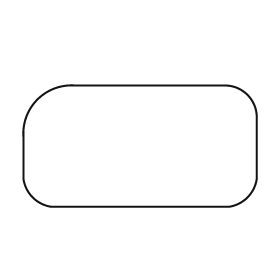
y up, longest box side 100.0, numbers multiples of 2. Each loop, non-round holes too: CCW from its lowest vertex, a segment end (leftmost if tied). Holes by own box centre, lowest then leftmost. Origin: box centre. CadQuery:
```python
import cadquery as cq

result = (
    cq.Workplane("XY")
    .moveTo(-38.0, -26.0)
    .lineTo(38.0, -26.0)
    .threePointArc((46.0, -22.0), (50.0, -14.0))
    .lineTo(50.0, 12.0)
    .threePointArc((46.0, 22.0), (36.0, 26.0))
    .lineTo(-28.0, 26.0)
    .threePointArc((-44.0, 20.0), (-50.0, 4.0))
    .lineTo(-50.0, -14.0)
    .threePointArc((-46.0, -22.0), (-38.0, -26.0))
    .close()
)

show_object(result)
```